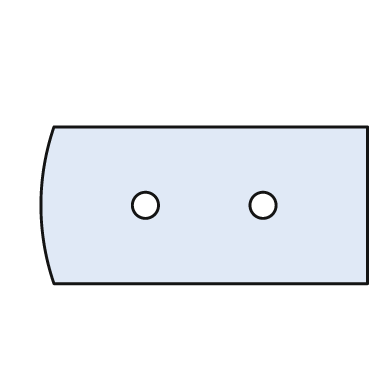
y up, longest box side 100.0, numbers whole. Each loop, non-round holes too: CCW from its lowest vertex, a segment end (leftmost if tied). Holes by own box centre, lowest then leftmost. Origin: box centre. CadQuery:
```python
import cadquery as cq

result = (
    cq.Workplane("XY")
    .moveTo(-46.0, -24.0)
    .lineTo(50.0, -24.0)
    .lineTo(50.0, 24.0)
    .lineTo(-46.0, 24.0)
    .threePointArc((-50.0, 0.0), (-46.0, -24.0))
    .close()
    .moveTo(-18.0, 0.0)
    .circle(4.0)
    .moveTo(18.0, 0.0)
    .circle(4.0)
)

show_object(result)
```